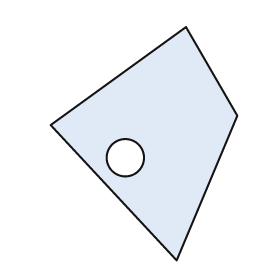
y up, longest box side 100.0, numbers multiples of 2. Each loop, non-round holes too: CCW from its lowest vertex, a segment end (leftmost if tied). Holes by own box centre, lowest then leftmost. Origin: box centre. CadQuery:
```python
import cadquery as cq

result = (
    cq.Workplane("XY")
    .moveTo(14.0, -50.0)
    .lineTo(40.0, 12.0)
    .lineTo(18.0, 50.0)
    .lineTo(-40.0, 8.0)
    .close()
    .moveTo(-8.0, -6.0)
    .circle(8.0)
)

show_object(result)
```